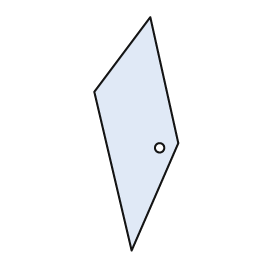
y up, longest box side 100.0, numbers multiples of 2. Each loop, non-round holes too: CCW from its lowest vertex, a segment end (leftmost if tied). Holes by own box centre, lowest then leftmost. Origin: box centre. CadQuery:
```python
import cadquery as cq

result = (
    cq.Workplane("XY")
    .moveTo(-2.0, -50.0)
    .lineTo(18.0, -4.0)
    .lineTo(6.0, 50.0)
    .lineTo(-18.0, 18.0)
    .close()
    .moveTo(10.0, -6.0)
    .circle(2.0)
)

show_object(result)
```